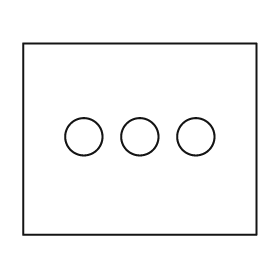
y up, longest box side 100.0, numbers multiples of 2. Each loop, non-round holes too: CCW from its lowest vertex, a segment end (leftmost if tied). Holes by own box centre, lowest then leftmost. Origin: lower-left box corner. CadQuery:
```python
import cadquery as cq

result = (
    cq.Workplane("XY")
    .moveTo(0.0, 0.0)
    .lineTo(100.0, 0.0)
    .lineTo(100.0, 82.0)
    .lineTo(0.0, 82.0)
    .close()
    .moveTo(26.0, 42.0)
    .circle(8.0)
    .moveTo(50.0, 42.0)
    .circle(8.0)
    .moveTo(74.0, 42.0)
    .circle(8.0)
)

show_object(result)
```